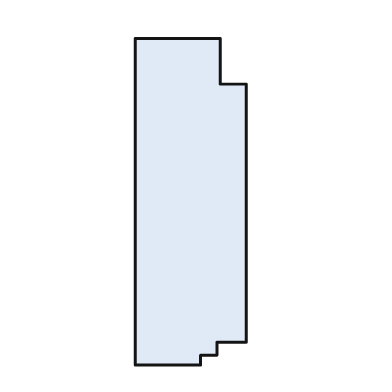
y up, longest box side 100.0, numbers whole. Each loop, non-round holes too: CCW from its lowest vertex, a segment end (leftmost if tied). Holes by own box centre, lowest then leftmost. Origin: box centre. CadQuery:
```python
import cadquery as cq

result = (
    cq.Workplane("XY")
    .moveTo(-17.0, -50.0)
    .lineTo(3.0, -50.0)
    .lineTo(3.0, -47.0)
    .lineTo(8.0, -47.0)
    .lineTo(8.0, -43.0)
    .lineTo(17.0, -43.0)
    .lineTo(17.0, 36.0)
    .lineTo(9.0, 36.0)
    .lineTo(9.0, 50.0)
    .lineTo(-17.0, 50.0)
    .close()
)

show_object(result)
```